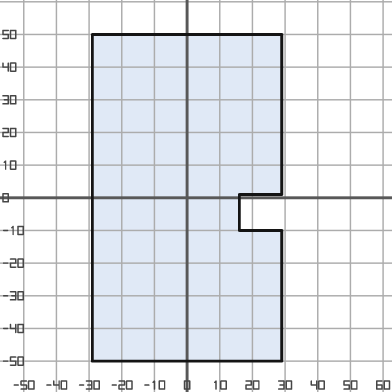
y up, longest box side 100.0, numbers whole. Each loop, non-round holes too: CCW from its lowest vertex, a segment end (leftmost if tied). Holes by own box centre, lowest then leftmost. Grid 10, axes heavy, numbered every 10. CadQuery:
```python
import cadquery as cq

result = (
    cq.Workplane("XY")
    .moveTo(-29.0, -50.0)
    .lineTo(29.0, -50.0)
    .lineTo(29.0, -10.0)
    .lineTo(16.0, -10.0)
    .lineTo(16.0, 1.0)
    .lineTo(29.0, 1.0)
    .lineTo(29.0, 50.0)
    .lineTo(-29.0, 50.0)
    .close()
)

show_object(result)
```